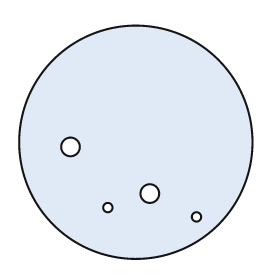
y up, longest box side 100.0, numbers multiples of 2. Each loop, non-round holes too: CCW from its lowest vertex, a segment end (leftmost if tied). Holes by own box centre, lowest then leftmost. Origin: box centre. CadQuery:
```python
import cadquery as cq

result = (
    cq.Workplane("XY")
    .moveTo(0.0, 0.0)
    .circle(50.0)
    .moveTo(26.0, -32.0)
    .circle(2.0)
    .moveTo(-12.0, -28.0)
    .circle(2.0)
    .moveTo(6.0, -22.0)
    .circle(4.0)
    .moveTo(-28.0, -2.0)
    .circle(4.0)
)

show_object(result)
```